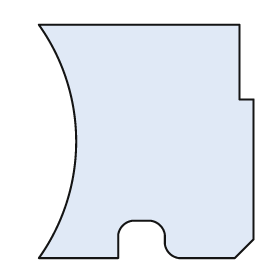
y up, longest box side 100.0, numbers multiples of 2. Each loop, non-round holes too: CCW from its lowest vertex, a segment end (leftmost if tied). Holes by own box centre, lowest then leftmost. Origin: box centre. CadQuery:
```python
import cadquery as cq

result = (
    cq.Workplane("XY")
    .moveTo(-46.0, -50.0)
    .lineTo(-12.0, -50.0)
    .lineTo(-12.0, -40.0)
    .threePointArc((-10.0, -36.0), (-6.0, -34.0))
    .lineTo(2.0, -34.0)
    .threePointArc((6.0, -36.0), (8.0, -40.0))
    .lineTo(8.0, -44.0)
    .threePointArc((10.0, -48.0), (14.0, -50.0))
    .lineTo(38.0, -50.0)
    .lineTo(46.0, -42.0)
    .lineTo(46.0, 18.0)
    .lineTo(40.0, 18.0)
    .lineTo(40.0, 50.0)
    .lineTo(-46.0, 50.0)
    .threePointArc((-30.0, 0.0), (-46.0, -50.0))
    .close()
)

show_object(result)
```